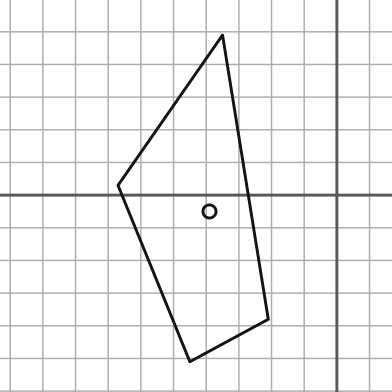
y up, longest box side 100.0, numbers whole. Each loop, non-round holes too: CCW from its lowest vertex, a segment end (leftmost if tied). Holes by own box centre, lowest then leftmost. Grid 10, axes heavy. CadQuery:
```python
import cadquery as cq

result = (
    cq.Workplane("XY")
    .moveTo(-45.0, -51.0)
    .lineTo(-21.0, -38.0)
    .lineTo(-35.0, 49.0)
    .lineTo(-67.0, 3.0)
    .close()
    .moveTo(-39.0, -5.0)
    .circle(2.0)
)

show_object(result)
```